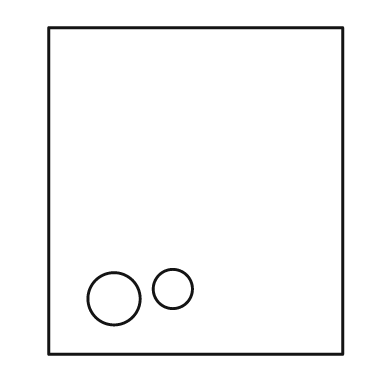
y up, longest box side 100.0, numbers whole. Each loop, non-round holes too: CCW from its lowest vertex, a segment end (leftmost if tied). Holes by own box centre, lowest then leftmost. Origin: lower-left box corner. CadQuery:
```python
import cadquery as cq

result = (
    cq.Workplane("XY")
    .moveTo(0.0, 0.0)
    .lineTo(90.0, 0.0)
    .lineTo(90.0, 100.0)
    .lineTo(0.0, 100.0)
    .close()
    .moveTo(20.0, 17.0)
    .circle(8.0)
    .moveTo(38.0, 20.0)
    .circle(6.0)
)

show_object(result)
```